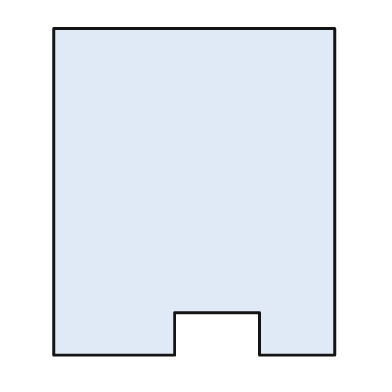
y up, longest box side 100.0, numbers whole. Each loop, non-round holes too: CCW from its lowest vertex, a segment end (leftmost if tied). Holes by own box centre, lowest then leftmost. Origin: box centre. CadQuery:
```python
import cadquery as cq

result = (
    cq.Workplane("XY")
    .moveTo(-43.0, -50.0)
    .lineTo(-6.0, -50.0)
    .lineTo(-6.0, -37.0)
    .lineTo(20.0, -37.0)
    .lineTo(20.0, -50.0)
    .lineTo(43.0, -50.0)
    .lineTo(43.0, 50.0)
    .lineTo(-43.0, 50.0)
    .close()
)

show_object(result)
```